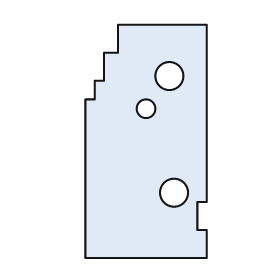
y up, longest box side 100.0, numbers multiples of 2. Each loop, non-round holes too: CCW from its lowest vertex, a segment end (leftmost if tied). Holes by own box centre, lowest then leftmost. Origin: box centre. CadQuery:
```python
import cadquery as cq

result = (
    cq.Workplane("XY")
    .moveTo(-26.0, -50.0)
    .lineTo(26.0, -50.0)
    .lineTo(26.0, -38.0)
    .lineTo(22.0, -38.0)
    .lineTo(22.0, -26.0)
    .lineTo(26.0, -26.0)
    .lineTo(26.0, 50.0)
    .lineTo(-12.0, 50.0)
    .lineTo(-12.0, 38.0)
    .lineTo(-18.0, 38.0)
    .lineTo(-18.0, 26.0)
    .lineTo(-22.0, 26.0)
    .lineTo(-22.0, 18.0)
    .lineTo(-26.0, 18.0)
    .close()
    .moveTo(12.0, -22.0)
    .circle(6.0)
    .moveTo(0.0, 14.0)
    .circle(4.0)
    .moveTo(10.0, 28.0)
    .circle(6.0)
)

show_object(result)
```